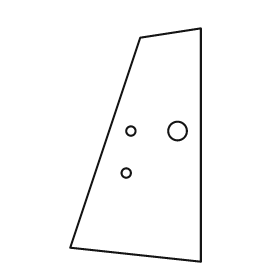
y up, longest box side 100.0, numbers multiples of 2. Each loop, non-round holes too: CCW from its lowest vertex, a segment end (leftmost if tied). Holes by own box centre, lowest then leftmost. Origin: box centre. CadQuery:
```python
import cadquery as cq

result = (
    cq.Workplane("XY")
    .moveTo(28.0, -50.0)
    .lineTo(28.0, 50.0)
    .lineTo(2.0, 46.0)
    .lineTo(-28.0, -44.0)
    .close()
    .moveTo(-4.0, -12.0)
    .circle(2.0)
    .moveTo(-2.0, 6.0)
    .circle(2.0)
    .moveTo(18.0, 6.0)
    .circle(4.0)
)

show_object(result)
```